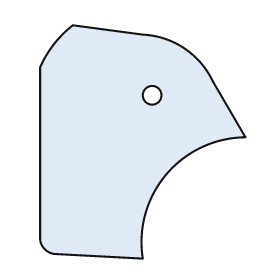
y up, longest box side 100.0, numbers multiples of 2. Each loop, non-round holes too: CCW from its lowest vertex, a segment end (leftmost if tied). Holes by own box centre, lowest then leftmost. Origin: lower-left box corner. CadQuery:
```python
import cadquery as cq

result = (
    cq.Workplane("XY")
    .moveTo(44.0, 0.0)
    .threePointArc((54.0, 36.0), (88.0, 52.0))
    .lineTo(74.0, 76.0)
    .threePointArc((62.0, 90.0), (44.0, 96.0))
    .lineTo(14.0, 100.0)
    .threePointArc((6.0, 92.0), (0.0, 82.0))
    .lineTo(0.0, 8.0)
    .threePointArc((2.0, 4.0), (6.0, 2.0))
    .close()
    .moveTo(48.0, 70.0)
    .circle(4.0)
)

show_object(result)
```